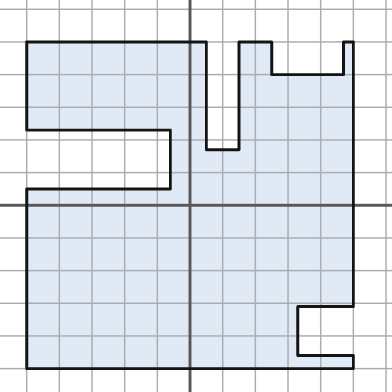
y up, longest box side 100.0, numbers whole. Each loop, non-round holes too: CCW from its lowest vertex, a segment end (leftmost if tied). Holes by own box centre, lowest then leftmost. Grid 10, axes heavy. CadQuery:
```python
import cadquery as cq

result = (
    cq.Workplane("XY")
    .moveTo(-50.0, -50.0)
    .lineTo(50.0, -50.0)
    .lineTo(50.0, -46.0)
    .lineTo(33.0, -46.0)
    .lineTo(33.0, -31.0)
    .lineTo(50.0, -31.0)
    .lineTo(50.0, 50.0)
    .lineTo(47.0, 50.0)
    .lineTo(47.0, 40.0)
    .lineTo(25.0, 40.0)
    .lineTo(25.0, 50.0)
    .lineTo(15.0, 50.0)
    .lineTo(15.0, 17.0)
    .lineTo(5.0, 17.0)
    .lineTo(5.0, 50.0)
    .lineTo(-50.0, 50.0)
    .lineTo(-50.0, 23.0)
    .lineTo(-6.0, 23.0)
    .lineTo(-6.0, 5.0)
    .lineTo(-50.0, 5.0)
    .close()
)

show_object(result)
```